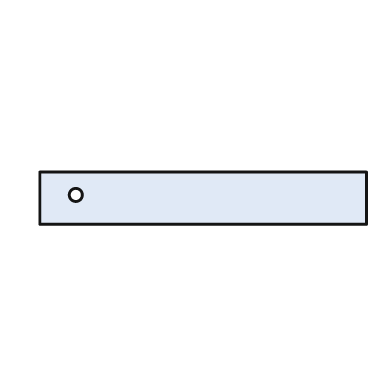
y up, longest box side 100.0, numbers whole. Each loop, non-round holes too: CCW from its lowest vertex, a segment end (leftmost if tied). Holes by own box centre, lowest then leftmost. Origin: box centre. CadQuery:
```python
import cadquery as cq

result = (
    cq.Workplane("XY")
    .moveTo(-50.0, -8.0)
    .lineTo(50.0, -8.0)
    .lineTo(50.0, 8.0)
    .lineTo(-50.0, 8.0)
    .close()
    .moveTo(-39.0, 1.0)
    .circle(2.0)
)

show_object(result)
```